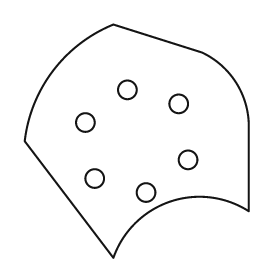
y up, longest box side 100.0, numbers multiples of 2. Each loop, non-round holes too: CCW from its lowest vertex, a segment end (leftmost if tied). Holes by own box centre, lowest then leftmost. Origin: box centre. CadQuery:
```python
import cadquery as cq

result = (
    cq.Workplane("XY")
    .moveTo(-10.0, -50.0)
    .threePointArc((14.0, -26.0), (48.0, -30.0))
    .lineTo(48.0, 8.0)
    .threePointArc((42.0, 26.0), (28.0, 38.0))
    .lineTo(-10.0, 50.0)
    .threePointArc((-36.0, 30.0), (-48.0, 0.0))
    .close()
    .moveTo(4.0, -22.0)
    .circle(4.0)
    .moveTo(-18.0, -16.0)
    .circle(4.0)
    .moveTo(22.0, -8.0)
    .circle(4.0)
    .moveTo(-22.0, 8.0)
    .circle(4.0)
    .moveTo(18.0, 16.0)
    .circle(4.0)
    .moveTo(-4.0, 22.0)
    .circle(4.0)
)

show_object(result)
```